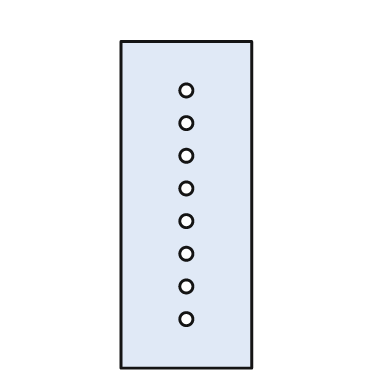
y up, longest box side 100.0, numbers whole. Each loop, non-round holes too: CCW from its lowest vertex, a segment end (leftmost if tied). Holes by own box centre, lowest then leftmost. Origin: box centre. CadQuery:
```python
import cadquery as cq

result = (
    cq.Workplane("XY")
    .moveTo(-20.0, -50.0)
    .lineTo(20.0, -50.0)
    .lineTo(20.0, 50.0)
    .lineTo(-20.0, 50.0)
    .close()
    .moveTo(0.0, -35.0)
    .circle(2.0)
    .moveTo(0.0, -25.0)
    .circle(2.0)
    .moveTo(0.0, -15.0)
    .circle(2.0)
    .moveTo(0.0, -5.0)
    .circle(2.0)
    .moveTo(0.0, 5.0)
    .circle(2.0)
    .moveTo(0.0, 15.0)
    .circle(2.0)
    .moveTo(0.0, 25.0)
    .circle(2.0)
    .moveTo(0.0, 35.0)
    .circle(2.0)
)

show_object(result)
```